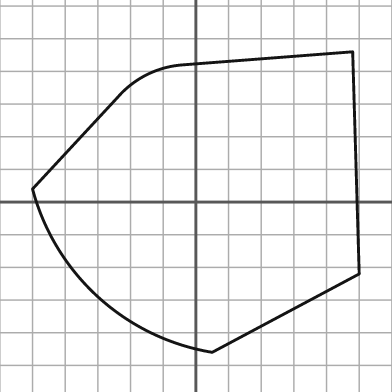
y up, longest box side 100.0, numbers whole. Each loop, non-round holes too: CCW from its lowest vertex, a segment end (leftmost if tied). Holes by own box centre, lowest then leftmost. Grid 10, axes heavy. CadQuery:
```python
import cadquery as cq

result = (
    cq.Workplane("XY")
    .moveTo(5.0, -46.0)
    .lineTo(50.0, -22.0)
    .lineTo(48.0, 46.0)
    .lineTo(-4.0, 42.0)
    .threePointArc((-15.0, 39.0), (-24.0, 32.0))
    .lineTo(-50.0, 4.0)
    .threePointArc((-30.0, -29.0), (5.0, -46.0))
    .close()
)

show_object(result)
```